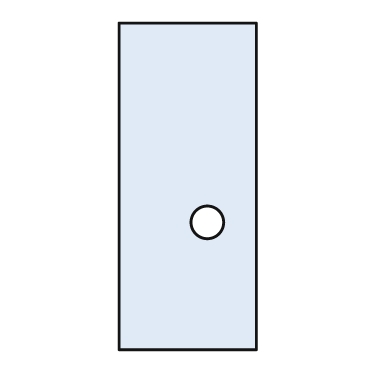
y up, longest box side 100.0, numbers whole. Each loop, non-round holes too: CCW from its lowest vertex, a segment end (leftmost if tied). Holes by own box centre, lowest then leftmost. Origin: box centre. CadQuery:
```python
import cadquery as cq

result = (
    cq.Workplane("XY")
    .moveTo(-21.0, -50.0)
    .lineTo(21.0, -50.0)
    .lineTo(21.0, 50.0)
    .lineTo(-21.0, 50.0)
    .close()
    .moveTo(6.0, -11.0)
    .circle(5.0)
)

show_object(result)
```